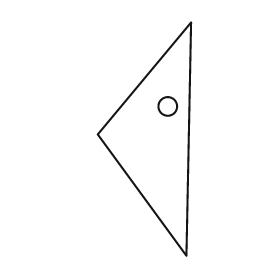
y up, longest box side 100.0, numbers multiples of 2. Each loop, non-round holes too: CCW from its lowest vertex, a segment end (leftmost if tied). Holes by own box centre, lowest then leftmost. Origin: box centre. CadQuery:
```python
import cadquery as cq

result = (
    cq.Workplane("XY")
    .moveTo(18.0, -50.0)
    .lineTo(20.0, 50.0)
    .lineTo(-20.0, 2.0)
    .close()
    .moveTo(10.0, 14.0)
    .circle(4.0)
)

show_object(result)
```